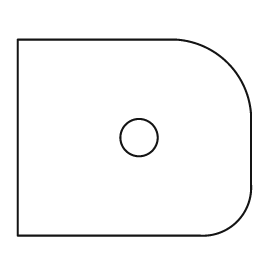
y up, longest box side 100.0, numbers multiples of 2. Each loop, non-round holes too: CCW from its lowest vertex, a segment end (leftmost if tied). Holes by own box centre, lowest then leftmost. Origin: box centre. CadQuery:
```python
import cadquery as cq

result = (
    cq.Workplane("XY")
    .moveTo(-50.0, -42.0)
    .lineTo(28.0, -42.0)
    .threePointArc((44.0, -36.0), (50.0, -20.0))
    .lineTo(50.0, 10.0)
    .threePointArc((40.0, 32.0), (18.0, 42.0))
    .lineTo(-50.0, 42.0)
    .close()
    .moveTo(2.0, 0.0)
    .circle(8.0)
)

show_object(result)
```